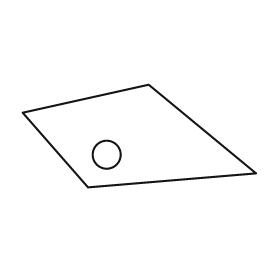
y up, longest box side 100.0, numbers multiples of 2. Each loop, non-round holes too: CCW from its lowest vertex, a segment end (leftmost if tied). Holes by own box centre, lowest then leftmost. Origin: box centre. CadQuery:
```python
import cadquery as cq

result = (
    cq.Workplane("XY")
    .moveTo(-22.0, -22.0)
    .lineTo(50.0, -16.0)
    .lineTo(4.0, 22.0)
    .lineTo(-50.0, 10.0)
    .close()
    .moveTo(-14.0, -8.0)
    .circle(6.0)
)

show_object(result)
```